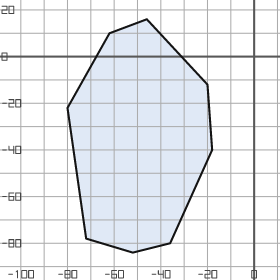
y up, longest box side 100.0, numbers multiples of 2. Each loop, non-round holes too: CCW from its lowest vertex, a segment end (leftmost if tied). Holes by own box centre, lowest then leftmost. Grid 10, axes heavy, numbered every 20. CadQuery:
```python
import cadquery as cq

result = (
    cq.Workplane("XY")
    .moveTo(-52.0, -84.0)
    .lineTo(-36.0, -80.0)
    .lineTo(-18.0, -40.0)
    .lineTo(-20.0, -12.0)
    .lineTo(-46.0, 16.0)
    .lineTo(-62.0, 10.0)
    .lineTo(-80.0, -22.0)
    .lineTo(-72.0, -78.0)
    .close()
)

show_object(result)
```